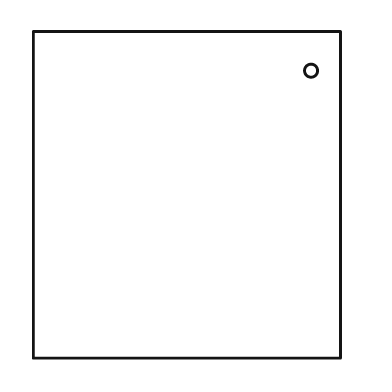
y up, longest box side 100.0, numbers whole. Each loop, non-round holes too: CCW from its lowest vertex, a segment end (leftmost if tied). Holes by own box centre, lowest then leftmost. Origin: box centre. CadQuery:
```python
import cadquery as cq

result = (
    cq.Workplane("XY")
    .moveTo(-47.0, -50.0)
    .lineTo(47.0, -50.0)
    .lineTo(47.0, 50.0)
    .lineTo(-47.0, 50.0)
    .close()
    .moveTo(38.0, 38.0)
    .circle(2.0)
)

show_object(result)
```